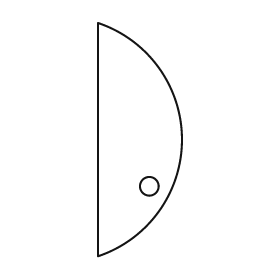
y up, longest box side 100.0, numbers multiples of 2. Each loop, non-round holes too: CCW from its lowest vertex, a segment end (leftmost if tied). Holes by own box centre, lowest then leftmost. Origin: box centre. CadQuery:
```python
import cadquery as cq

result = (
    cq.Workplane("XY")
    .moveTo(-18.0, -50.0)
    .threePointArc((18.0, 0.0), (-18.0, 50.0))
    .close()
    .moveTo(4.0, -20.0)
    .circle(4.0)
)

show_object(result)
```